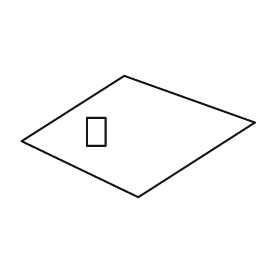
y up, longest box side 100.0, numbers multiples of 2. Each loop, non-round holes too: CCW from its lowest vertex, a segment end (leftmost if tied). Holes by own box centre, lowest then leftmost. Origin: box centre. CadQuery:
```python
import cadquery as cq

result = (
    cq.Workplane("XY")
    .moveTo(0.0, -26.0)
    .lineTo(50.0, 6.0)
    .lineTo(-6.0, 26.0)
    .lineTo(-50.0, -2.0)
    .close()
    .moveTo(-22.0, -4.0)
    .lineTo(-14.0, -4.0)
    .lineTo(-14.0, 8.0)
    .lineTo(-22.0, 8.0)
    .close()
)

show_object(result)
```